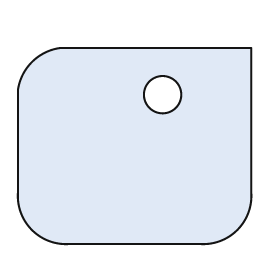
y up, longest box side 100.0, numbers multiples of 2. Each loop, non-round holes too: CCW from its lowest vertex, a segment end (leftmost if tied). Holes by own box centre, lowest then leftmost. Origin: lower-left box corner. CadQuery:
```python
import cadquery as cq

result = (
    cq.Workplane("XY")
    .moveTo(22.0, 0.0)
    .lineTo(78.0, 0.0)
    .threePointArc((94.0, 6.0), (100.0, 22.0))
    .lineTo(100.0, 84.0)
    .lineTo(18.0, 84.0)
    .threePointArc((6.0, 78.0), (0.0, 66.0))
    .lineTo(0.0, 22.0)
    .threePointArc((6.0, 6.0), (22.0, 0.0))
    .close()
    .moveTo(62.0, 64.0)
    .circle(8.0)
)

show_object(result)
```